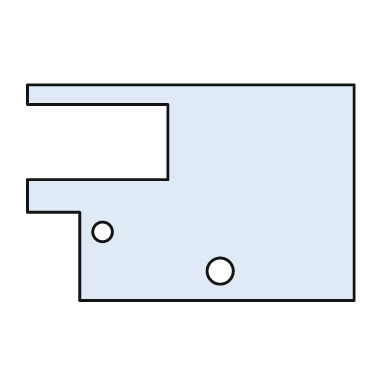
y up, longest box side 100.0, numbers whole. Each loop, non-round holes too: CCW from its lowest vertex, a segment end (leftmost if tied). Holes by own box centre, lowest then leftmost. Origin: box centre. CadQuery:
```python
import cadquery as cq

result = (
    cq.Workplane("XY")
    .moveTo(-34.0, -33.0)
    .lineTo(50.0, -33.0)
    .lineTo(50.0, 33.0)
    .lineTo(-50.0, 33.0)
    .lineTo(-50.0, 27.0)
    .lineTo(-7.0, 27.0)
    .lineTo(-7.0, 4.0)
    .lineTo(-50.0, 4.0)
    .lineTo(-50.0, -6.0)
    .lineTo(-34.0, -6.0)
    .close()
    .moveTo(9.0, -24.0)
    .circle(4.0)
    .moveTo(-27.0, -12.0)
    .circle(3.0)
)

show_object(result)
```